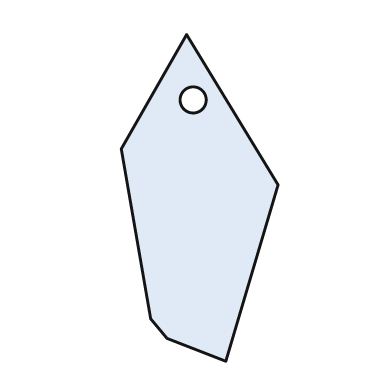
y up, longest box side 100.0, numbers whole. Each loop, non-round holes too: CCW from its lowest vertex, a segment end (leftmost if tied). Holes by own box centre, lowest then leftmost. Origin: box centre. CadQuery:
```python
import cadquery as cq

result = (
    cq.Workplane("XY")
    .moveTo(8.0, -50.0)
    .lineTo(24.0, 4.0)
    .lineTo(-4.0, 50.0)
    .lineTo(-24.0, 15.0)
    .lineTo(-15.0, -37.0)
    .lineTo(-10.0, -43.0)
    .close()
    .moveTo(-2.0, 30.0)
    .circle(4.0)
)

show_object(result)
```